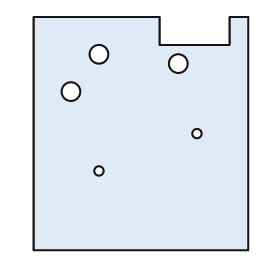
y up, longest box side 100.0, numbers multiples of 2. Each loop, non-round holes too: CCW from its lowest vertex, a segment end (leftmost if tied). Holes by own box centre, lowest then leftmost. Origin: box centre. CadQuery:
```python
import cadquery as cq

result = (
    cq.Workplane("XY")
    .moveTo(-46.0, -50.0)
    .lineTo(46.0, -50.0)
    .lineTo(46.0, 50.0)
    .lineTo(38.0, 50.0)
    .lineTo(38.0, 38.0)
    .lineTo(8.0, 38.0)
    .lineTo(8.0, 50.0)
    .lineTo(-46.0, 50.0)
    .close()
    .moveTo(-18.0, -16.0)
    .circle(2.0)
    .moveTo(24.0, 0.0)
    .circle(2.0)
    .moveTo(-30.0, 18.0)
    .circle(4.0)
    .moveTo(16.0, 30.0)
    .circle(4.0)
    .moveTo(-18.0, 34.0)
    .circle(4.0)
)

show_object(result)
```